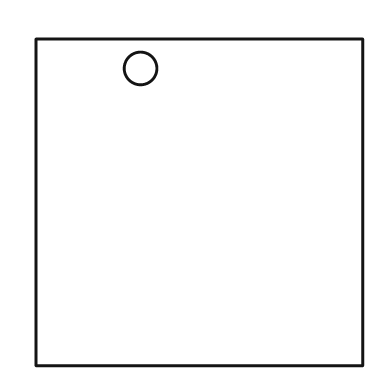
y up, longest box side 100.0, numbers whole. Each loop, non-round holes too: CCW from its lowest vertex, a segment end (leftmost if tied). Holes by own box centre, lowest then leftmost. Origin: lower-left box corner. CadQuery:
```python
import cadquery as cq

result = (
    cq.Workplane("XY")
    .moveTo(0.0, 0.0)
    .lineTo(100.0, 0.0)
    .lineTo(100.0, 100.0)
    .lineTo(0.0, 100.0)
    .close()
    .moveTo(32.0, 91.0)
    .circle(5.0)
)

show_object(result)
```